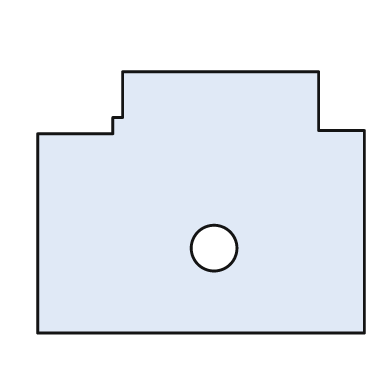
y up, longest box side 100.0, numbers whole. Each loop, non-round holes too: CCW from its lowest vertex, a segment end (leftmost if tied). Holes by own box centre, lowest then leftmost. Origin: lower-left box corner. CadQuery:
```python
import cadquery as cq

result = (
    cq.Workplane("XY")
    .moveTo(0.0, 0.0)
    .lineTo(100.0, 0.0)
    .lineTo(100.0, 62.0)
    .lineTo(86.0, 62.0)
    .lineTo(86.0, 80.0)
    .lineTo(26.0, 80.0)
    .lineTo(26.0, 66.0)
    .lineTo(23.0, 66.0)
    .lineTo(23.0, 61.0)
    .lineTo(0.0, 61.0)
    .close()
    .moveTo(54.0, 26.0)
    .circle(7.0)
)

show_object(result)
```